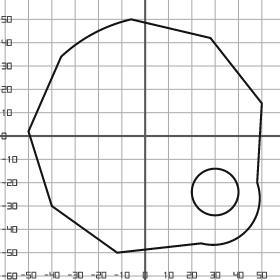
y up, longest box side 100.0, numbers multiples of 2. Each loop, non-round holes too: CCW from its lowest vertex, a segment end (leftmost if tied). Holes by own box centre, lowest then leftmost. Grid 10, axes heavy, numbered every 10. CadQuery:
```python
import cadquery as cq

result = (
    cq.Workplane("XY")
    .moveTo(-12.0, -50.0)
    .lineTo(24.0, -46.0)
    .threePointArc((44.0, -40.0), (48.0, -20.0))
    .lineTo(50.0, 14.0)
    .lineTo(28.0, 42.0)
    .lineTo(-6.0, 50.0)
    .threePointArc((-22.0, 44.0), (-36.0, 34.0))
    .lineTo(-50.0, 2.0)
    .lineTo(-40.0, -30.0)
    .close()
    .moveTo(30.0, -24.0)
    .circle(10.0)
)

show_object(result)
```